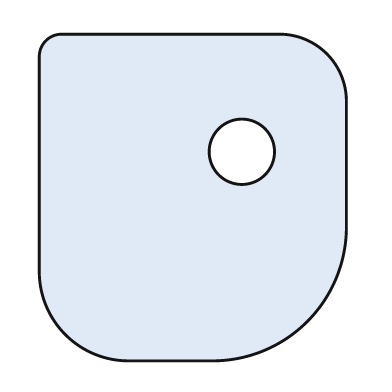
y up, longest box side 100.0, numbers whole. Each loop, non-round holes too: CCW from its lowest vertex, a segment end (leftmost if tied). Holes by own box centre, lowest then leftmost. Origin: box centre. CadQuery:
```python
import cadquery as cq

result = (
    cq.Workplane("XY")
    .moveTo(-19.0, -50.0)
    .lineTo(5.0, -50.0)
    .threePointArc((35.0, -38.0), (47.0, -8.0))
    .lineTo(47.0, 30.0)
    .threePointArc((41.0, 44.0), (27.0, 50.0))
    .lineTo(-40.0, 50.0)
    .threePointArc((-45.0, 48.0), (-47.0, 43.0))
    .lineTo(-47.0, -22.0)
    .threePointArc((-39.0, -42.0), (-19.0, -50.0))
    .close()
    .moveTo(15.0, 14.0)
    .circle(10.0)
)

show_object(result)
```